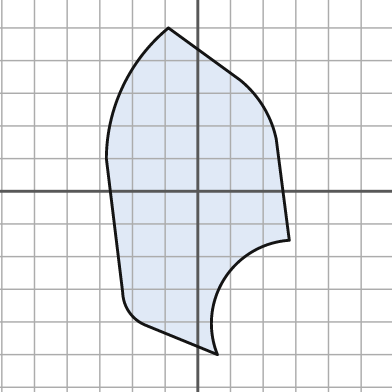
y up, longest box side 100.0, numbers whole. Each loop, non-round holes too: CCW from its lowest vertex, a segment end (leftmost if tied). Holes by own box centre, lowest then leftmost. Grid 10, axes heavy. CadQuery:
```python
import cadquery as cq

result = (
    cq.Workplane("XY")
    .moveTo(6.0, -50.0)
    .threePointArc((8.0, -27.0), (28.0, -15.0))
    .lineTo(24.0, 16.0)
    .threePointArc((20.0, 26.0), (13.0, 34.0))
    .lineTo(-9.0, 50.0)
    .threePointArc((-23.0, 32.0), (-28.0, 10.0))
    .lineTo(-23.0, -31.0)
    .threePointArc((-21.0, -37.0), (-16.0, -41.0))
    .close()
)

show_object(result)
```